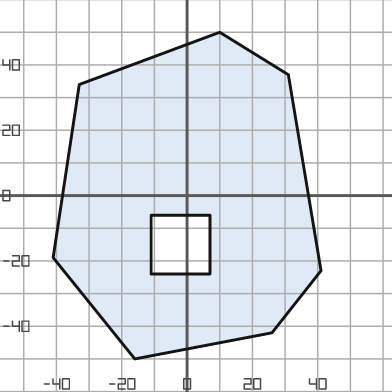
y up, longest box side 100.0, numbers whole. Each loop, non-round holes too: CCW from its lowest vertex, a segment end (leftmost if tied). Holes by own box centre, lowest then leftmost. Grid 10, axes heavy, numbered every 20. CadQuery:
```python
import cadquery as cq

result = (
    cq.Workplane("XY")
    .moveTo(-16.0, -50.0)
    .lineTo(26.0, -42.0)
    .lineTo(41.0, -23.0)
    .lineTo(31.0, 37.0)
    .lineTo(10.0, 50.0)
    .lineTo(-33.0, 34.0)
    .lineTo(-41.0, -19.0)
    .close()
    .moveTo(-11.0, -24.0)
    .lineTo(7.0, -24.0)
    .lineTo(7.0, -6.0)
    .lineTo(-11.0, -6.0)
    .close()
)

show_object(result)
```